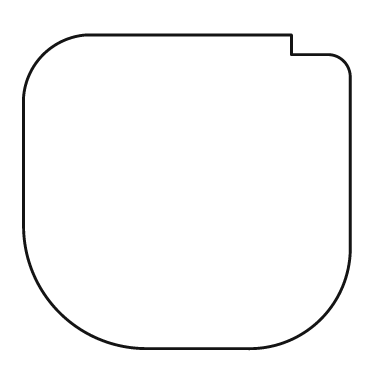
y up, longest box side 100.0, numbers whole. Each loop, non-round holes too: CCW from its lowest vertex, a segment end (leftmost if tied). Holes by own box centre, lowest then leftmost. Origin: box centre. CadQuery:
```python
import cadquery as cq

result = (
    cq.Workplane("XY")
    .moveTo(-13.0, -48.0)
    .lineTo(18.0, -48.0)
    .threePointArc((41.0, -39.0), (50.0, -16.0))
    .lineTo(50.0, 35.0)
    .threePointArc((48.0, 40.0), (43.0, 42.0))
    .lineTo(32.0, 42.0)
    .lineTo(32.0, 48.0)
    .lineTo(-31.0, 48.0)
    .threePointArc((-44.0, 42.0), (-50.0, 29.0))
    .lineTo(-50.0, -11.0)
    .threePointArc((-39.0, -37.0), (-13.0, -48.0))
    .close()
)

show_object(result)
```